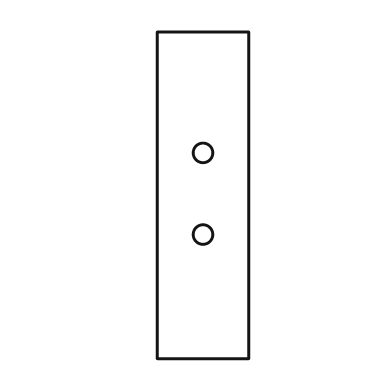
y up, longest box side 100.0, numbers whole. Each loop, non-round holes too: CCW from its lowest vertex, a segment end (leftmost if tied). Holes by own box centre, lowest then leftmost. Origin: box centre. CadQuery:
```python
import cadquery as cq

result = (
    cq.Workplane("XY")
    .moveTo(-14.0, -50.0)
    .lineTo(14.0, -50.0)
    .lineTo(14.0, 50.0)
    .lineTo(-14.0, 50.0)
    .close()
    .moveTo(0.0, -12.0)
    .circle(3.0)
    .moveTo(0.0, 13.0)
    .circle(3.0)
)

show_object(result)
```